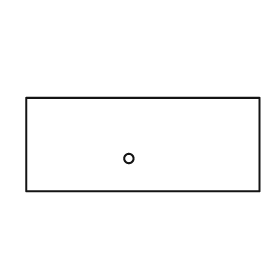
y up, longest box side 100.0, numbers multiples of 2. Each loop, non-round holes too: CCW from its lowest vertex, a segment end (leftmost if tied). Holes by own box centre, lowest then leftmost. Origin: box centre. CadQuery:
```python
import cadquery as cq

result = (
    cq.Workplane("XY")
    .moveTo(-50.0, -20.0)
    .lineTo(50.0, -20.0)
    .lineTo(50.0, 20.0)
    .lineTo(-50.0, 20.0)
    .close()
    .moveTo(-6.0, -6.0)
    .circle(2.0)
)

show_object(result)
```